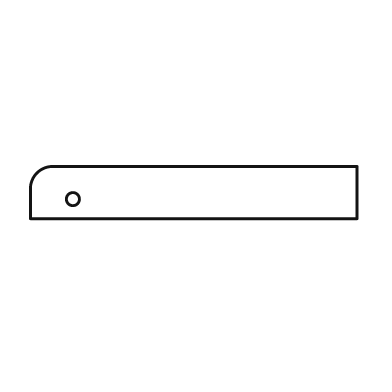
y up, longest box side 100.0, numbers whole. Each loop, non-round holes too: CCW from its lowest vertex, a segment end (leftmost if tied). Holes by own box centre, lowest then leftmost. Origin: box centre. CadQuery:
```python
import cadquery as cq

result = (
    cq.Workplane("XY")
    .moveTo(-50.0, -8.0)
    .lineTo(50.0, -8.0)
    .lineTo(50.0, 8.0)
    .lineTo(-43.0, 8.0)
    .threePointArc((-48.0, 6.0), (-50.0, 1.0))
    .close()
    .moveTo(-37.0, -2.0)
    .circle(2.0)
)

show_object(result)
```